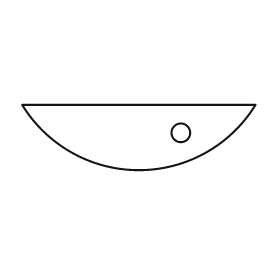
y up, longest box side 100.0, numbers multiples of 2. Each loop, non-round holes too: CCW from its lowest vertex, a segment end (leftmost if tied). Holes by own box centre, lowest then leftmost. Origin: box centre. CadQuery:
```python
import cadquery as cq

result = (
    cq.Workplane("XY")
    .moveTo(-50.0, 14.0)
    .threePointArc((0.0, -14.0), (50.0, 14.0))
    .close()
    .moveTo(18.0, 2.0)
    .circle(4.0)
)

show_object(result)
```